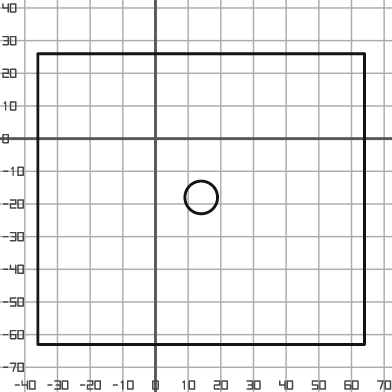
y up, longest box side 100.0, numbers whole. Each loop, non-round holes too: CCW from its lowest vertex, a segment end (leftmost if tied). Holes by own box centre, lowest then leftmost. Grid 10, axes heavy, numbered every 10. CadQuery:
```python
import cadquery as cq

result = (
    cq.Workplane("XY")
    .moveTo(-36.0, -63.0)
    .lineTo(64.0, -63.0)
    .lineTo(64.0, 26.0)
    .lineTo(-36.0, 26.0)
    .close()
    .moveTo(14.0, -18.0)
    .circle(5.0)
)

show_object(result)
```